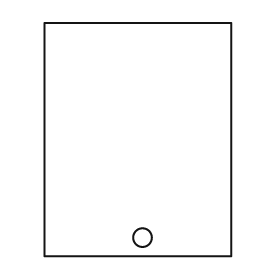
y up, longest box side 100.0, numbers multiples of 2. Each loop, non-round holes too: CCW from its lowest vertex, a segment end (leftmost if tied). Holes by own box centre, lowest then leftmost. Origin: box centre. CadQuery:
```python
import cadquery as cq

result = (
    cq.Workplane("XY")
    .moveTo(-40.0, -50.0)
    .lineTo(40.0, -50.0)
    .lineTo(40.0, 50.0)
    .lineTo(-40.0, 50.0)
    .close()
    .moveTo(2.0, -42.0)
    .circle(4.0)
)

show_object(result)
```